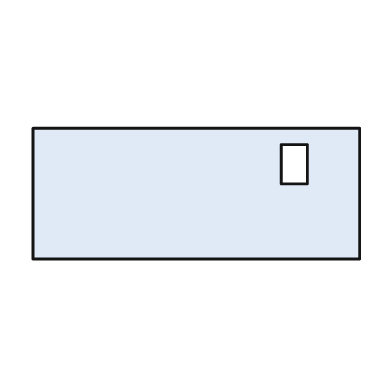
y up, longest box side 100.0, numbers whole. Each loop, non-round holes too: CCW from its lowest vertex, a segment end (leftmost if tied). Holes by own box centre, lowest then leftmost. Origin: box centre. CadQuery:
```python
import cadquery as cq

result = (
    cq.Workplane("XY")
    .moveTo(-50.0, -20.0)
    .lineTo(50.0, -20.0)
    .lineTo(50.0, 20.0)
    .lineTo(-50.0, 20.0)
    .close()
    .moveTo(26.0, 3.0)
    .lineTo(34.0, 3.0)
    .lineTo(34.0, 15.0)
    .lineTo(26.0, 15.0)
    .close()
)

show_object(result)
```